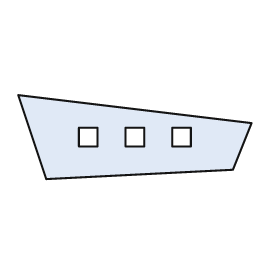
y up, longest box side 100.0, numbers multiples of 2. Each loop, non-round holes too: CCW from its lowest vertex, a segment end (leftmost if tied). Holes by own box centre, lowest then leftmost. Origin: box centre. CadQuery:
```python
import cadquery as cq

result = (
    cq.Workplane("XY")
    .moveTo(-38.0, -18.0)
    .lineTo(42.0, -14.0)
    .lineTo(50.0, 6.0)
    .lineTo(-50.0, 18.0)
    .close()
    .moveTo(-24.0, -4.0)
    .lineTo(-16.0, -4.0)
    .lineTo(-16.0, 4.0)
    .lineTo(-24.0, 4.0)
    .close()
    .moveTo(-4.0, -4.0)
    .lineTo(4.0, -4.0)
    .lineTo(4.0, 4.0)
    .lineTo(-4.0, 4.0)
    .close()
    .moveTo(16.0, -4.0)
    .lineTo(24.0, -4.0)
    .lineTo(24.0, 4.0)
    .lineTo(16.0, 4.0)
    .close()
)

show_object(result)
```